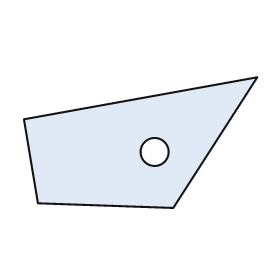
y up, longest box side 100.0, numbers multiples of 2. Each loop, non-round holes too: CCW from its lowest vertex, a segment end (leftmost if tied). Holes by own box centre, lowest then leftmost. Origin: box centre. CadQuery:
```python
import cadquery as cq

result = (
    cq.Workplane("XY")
    .moveTo(14.0, -28.0)
    .lineTo(50.0, 28.0)
    .lineTo(-50.0, 10.0)
    .lineTo(-44.0, -26.0)
    .close()
    .moveTo(6.0, -4.0)
    .circle(6.0)
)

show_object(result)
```